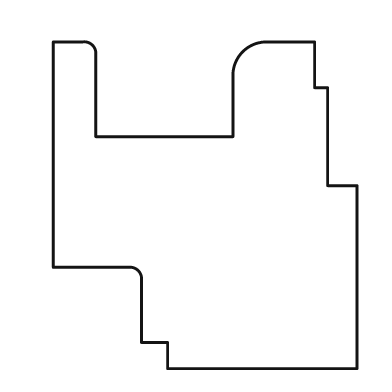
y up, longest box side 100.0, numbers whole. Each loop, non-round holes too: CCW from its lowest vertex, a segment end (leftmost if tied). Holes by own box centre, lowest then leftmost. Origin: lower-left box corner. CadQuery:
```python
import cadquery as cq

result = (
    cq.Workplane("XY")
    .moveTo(35.0, 0.0)
    .lineTo(93.0, 0.0)
    .lineTo(93.0, 56.0)
    .lineTo(84.0, 56.0)
    .lineTo(84.0, 86.0)
    .lineTo(80.0, 86.0)
    .lineTo(80.0, 100.0)
    .lineTo(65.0, 100.0)
    .threePointArc((58.0, 97.0), (55.0, 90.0))
    .lineTo(55.0, 71.0)
    .lineTo(13.0, 71.0)
    .lineTo(13.0, 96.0)
    .threePointArc((12.0, 99.0), (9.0, 100.0))
    .lineTo(0.0, 100.0)
    .lineTo(0.0, 31.0)
    .lineTo(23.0, 31.0)
    .threePointArc((26.0, 30.0), (27.0, 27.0))
    .lineTo(27.0, 8.0)
    .lineTo(35.0, 8.0)
    .close()
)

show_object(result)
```